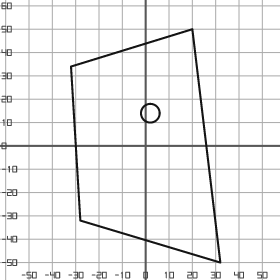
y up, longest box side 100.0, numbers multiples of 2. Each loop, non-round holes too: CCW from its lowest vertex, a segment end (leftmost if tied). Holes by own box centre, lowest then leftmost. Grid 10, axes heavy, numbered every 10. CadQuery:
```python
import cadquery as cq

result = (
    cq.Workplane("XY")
    .moveTo(32.0, -50.0)
    .lineTo(20.0, 50.0)
    .lineTo(-32.0, 34.0)
    .lineTo(-28.0, -32.0)
    .close()
    .moveTo(2.0, 14.0)
    .circle(4.0)
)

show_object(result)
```